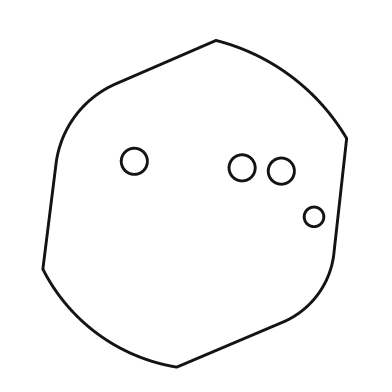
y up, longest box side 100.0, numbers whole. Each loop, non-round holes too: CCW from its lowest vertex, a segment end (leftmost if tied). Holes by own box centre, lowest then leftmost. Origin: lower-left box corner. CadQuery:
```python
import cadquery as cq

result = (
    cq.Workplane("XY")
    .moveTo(41.0, 0.0)
    .lineTo(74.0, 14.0)
    .threePointArc((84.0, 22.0), (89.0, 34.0))
    .lineTo(93.0, 70.0)
    .threePointArc((76.0, 89.0), (53.0, 100.0))
    .lineTo(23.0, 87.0)
    .threePointArc((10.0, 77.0), (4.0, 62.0))
    .lineTo(0.0, 30.0)
    .threePointArc((17.0, 10.0), (41.0, 0.0))
    .close()
    .moveTo(83.0, 46.0)
    .circle(3.0)
    .moveTo(73.0, 60.0)
    .circle(4.0)
    .moveTo(61.0, 61.0)
    .circle(4.0)
    .moveTo(28.0, 63.0)
    .circle(4.0)
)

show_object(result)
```